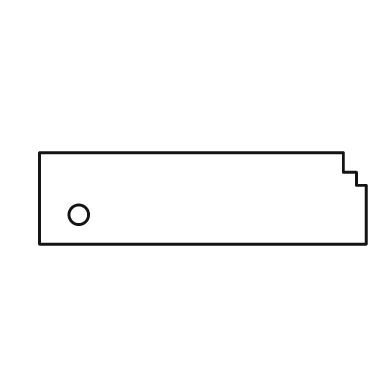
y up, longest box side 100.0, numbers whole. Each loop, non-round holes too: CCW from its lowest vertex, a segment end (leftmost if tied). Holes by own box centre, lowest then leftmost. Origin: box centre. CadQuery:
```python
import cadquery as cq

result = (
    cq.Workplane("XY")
    .moveTo(-50.0, -14.0)
    .lineTo(50.0, -14.0)
    .lineTo(50.0, 4.0)
    .lineTo(47.0, 4.0)
    .lineTo(47.0, 8.0)
    .lineTo(43.0, 8.0)
    .lineTo(43.0, 14.0)
    .lineTo(-50.0, 14.0)
    .close()
    .moveTo(-38.0, -5.0)
    .circle(3.0)
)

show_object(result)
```